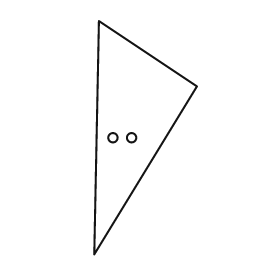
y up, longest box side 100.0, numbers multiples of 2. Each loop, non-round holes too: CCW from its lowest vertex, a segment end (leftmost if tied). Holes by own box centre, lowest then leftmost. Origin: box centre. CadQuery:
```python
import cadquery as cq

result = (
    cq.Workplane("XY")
    .moveTo(-22.0, -50.0)
    .lineTo(22.0, 22.0)
    .lineTo(-20.0, 50.0)
    .close()
    .moveTo(-14.0, 0.0)
    .circle(2.0)
    .moveTo(-6.0, 0.0)
    .circle(2.0)
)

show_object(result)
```